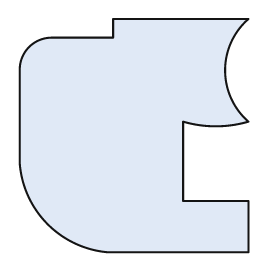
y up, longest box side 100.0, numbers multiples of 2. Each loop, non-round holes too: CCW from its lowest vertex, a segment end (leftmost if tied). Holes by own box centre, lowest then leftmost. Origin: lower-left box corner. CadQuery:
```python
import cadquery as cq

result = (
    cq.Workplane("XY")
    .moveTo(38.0, 0.0)
    .lineTo(98.0, 0.0)
    .lineTo(98.0, 22.0)
    .lineTo(70.0, 22.0)
    .lineTo(70.0, 56.0)
    .threePointArc((84.0, 54.0), (98.0, 56.0))
    .threePointArc((88.0, 78.0), (98.0, 100.0))
    .lineTo(40.0, 100.0)
    .lineTo(40.0, 92.0)
    .lineTo(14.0, 92.0)
    .threePointArc((4.0, 88.0), (0.0, 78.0))
    .lineTo(0.0, 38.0)
    .threePointArc((12.0, 12.0), (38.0, 0.0))
    .close()
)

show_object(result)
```